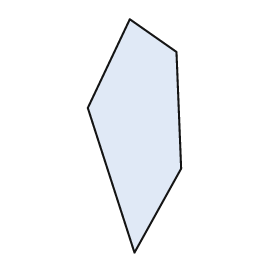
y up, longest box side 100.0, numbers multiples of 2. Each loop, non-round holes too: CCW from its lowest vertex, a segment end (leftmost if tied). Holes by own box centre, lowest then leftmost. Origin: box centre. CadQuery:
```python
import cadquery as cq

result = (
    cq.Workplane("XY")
    .moveTo(0.0, -50.0)
    .lineTo(20.0, -14.0)
    .lineTo(18.0, 36.0)
    .lineTo(-2.0, 50.0)
    .lineTo(-20.0, 12.0)
    .close()
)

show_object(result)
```